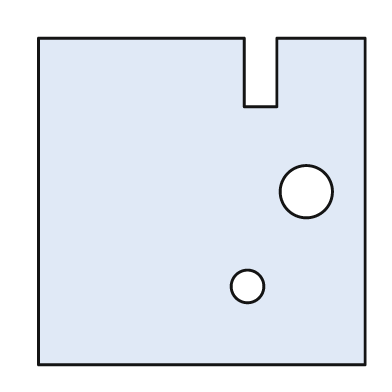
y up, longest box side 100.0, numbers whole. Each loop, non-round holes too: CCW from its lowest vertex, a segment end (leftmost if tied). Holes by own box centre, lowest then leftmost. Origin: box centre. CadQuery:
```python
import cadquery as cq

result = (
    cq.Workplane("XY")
    .moveTo(-50.0, -50.0)
    .lineTo(50.0, -50.0)
    .lineTo(50.0, 50.0)
    .lineTo(23.0, 50.0)
    .lineTo(23.0, 29.0)
    .lineTo(13.0, 29.0)
    .lineTo(13.0, 50.0)
    .lineTo(-50.0, 50.0)
    .close()
    .moveTo(14.0, -26.0)
    .circle(5.0)
    .moveTo(32.0, 3.0)
    .circle(8.0)
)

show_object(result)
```